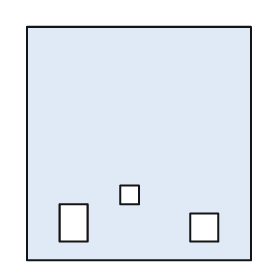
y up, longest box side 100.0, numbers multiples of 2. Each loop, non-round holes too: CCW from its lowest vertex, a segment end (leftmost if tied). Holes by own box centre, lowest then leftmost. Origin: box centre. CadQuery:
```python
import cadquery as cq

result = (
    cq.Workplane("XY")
    .moveTo(-48.0, -50.0)
    .lineTo(48.0, -50.0)
    .lineTo(48.0, 50.0)
    .lineTo(-48.0, 50.0)
    .close()
    .moveTo(22.0, -42.0)
    .lineTo(34.0, -42.0)
    .lineTo(34.0, -30.0)
    .lineTo(22.0, -30.0)
    .close()
    .moveTo(-34.0, -42.0)
    .lineTo(-22.0, -42.0)
    .lineTo(-22.0, -26.0)
    .lineTo(-34.0, -26.0)
    .close()
    .moveTo(-8.0, -26.0)
    .lineTo(0.0, -26.0)
    .lineTo(0.0, -18.0)
    .lineTo(-8.0, -18.0)
    .close()
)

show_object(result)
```